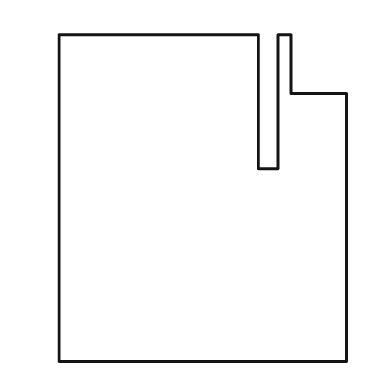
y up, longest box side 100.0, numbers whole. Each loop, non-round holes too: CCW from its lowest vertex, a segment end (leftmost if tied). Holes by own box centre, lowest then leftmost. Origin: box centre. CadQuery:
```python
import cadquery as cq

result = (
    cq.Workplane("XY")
    .moveTo(-44.0, -50.0)
    .lineTo(44.0, -50.0)
    .lineTo(44.0, 32.0)
    .lineTo(27.0, 32.0)
    .lineTo(27.0, 50.0)
    .lineTo(23.0, 50.0)
    .lineTo(23.0, 9.0)
    .lineTo(17.0, 9.0)
    .lineTo(17.0, 50.0)
    .lineTo(-44.0, 50.0)
    .close()
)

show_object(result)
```